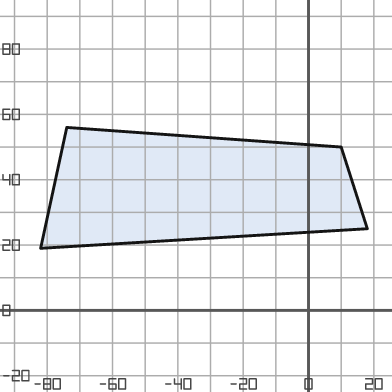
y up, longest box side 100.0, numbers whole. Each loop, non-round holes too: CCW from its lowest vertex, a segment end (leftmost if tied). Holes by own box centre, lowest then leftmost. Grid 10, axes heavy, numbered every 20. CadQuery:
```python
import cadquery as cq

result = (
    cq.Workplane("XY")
    .moveTo(-82.0, 19.0)
    .lineTo(18.0, 25.0)
    .lineTo(10.0, 50.0)
    .lineTo(-74.0, 56.0)
    .close()
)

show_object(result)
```